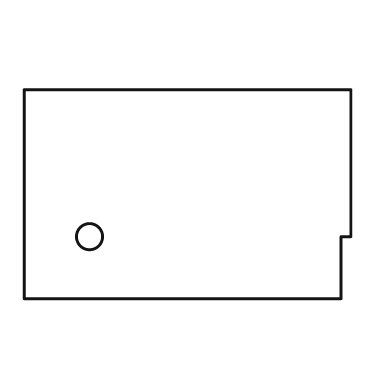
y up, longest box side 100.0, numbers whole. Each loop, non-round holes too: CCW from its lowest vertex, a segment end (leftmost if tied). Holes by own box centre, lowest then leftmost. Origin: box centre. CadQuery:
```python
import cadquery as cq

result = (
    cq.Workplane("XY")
    .moveTo(-50.0, -32.0)
    .lineTo(47.0, -32.0)
    .lineTo(47.0, -13.0)
    .lineTo(50.0, -13.0)
    .lineTo(50.0, 32.0)
    .lineTo(-50.0, 32.0)
    .close()
    .moveTo(-30.0, -13.0)
    .circle(4.0)
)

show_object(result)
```